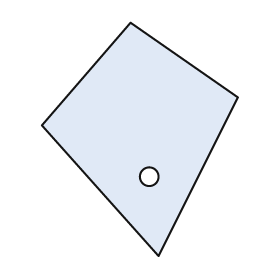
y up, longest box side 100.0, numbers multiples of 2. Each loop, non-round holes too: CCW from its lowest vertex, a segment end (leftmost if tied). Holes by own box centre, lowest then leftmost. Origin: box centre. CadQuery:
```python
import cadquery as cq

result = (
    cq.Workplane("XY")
    .moveTo(8.0, -50.0)
    .lineTo(42.0, 18.0)
    .lineTo(-4.0, 50.0)
    .lineTo(-42.0, 6.0)
    .close()
    .moveTo(4.0, -16.0)
    .circle(4.0)
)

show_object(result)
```